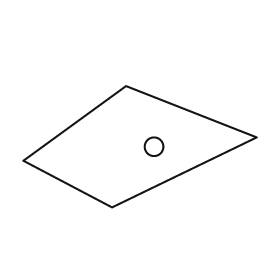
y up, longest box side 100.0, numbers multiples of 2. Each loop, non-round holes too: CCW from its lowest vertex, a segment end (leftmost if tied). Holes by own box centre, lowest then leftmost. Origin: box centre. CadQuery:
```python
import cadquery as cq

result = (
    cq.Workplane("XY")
    .moveTo(-12.0, -26.0)
    .lineTo(50.0, 4.0)
    .lineTo(-6.0, 26.0)
    .lineTo(-50.0, -6.0)
    .close()
    .moveTo(6.0, 0.0)
    .circle(4.0)
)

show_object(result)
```